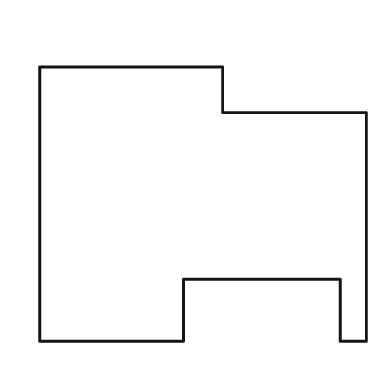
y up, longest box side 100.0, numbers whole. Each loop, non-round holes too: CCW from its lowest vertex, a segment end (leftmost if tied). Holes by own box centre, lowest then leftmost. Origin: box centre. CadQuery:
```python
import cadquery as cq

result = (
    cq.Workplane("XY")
    .moveTo(-50.0, -42.0)
    .lineTo(-6.0, -42.0)
    .lineTo(-6.0, -23.0)
    .lineTo(42.0, -23.0)
    .lineTo(42.0, -42.0)
    .lineTo(50.0, -42.0)
    .lineTo(50.0, 28.0)
    .lineTo(6.0, 28.0)
    .lineTo(6.0, 42.0)
    .lineTo(-50.0, 42.0)
    .close()
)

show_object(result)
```